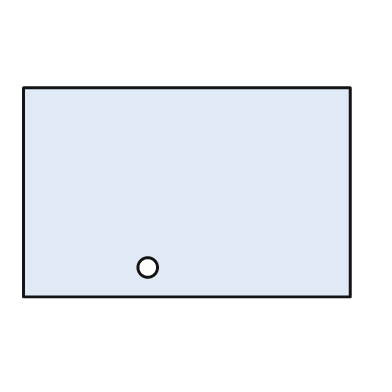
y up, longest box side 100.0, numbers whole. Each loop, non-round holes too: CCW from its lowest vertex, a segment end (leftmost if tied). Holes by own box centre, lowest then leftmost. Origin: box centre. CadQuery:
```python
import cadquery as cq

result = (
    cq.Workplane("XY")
    .moveTo(-50.0, -32.0)
    .lineTo(50.0, -32.0)
    .lineTo(50.0, 32.0)
    .lineTo(-50.0, 32.0)
    .close()
    .moveTo(-12.0, -23.0)
    .circle(3.0)
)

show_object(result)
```